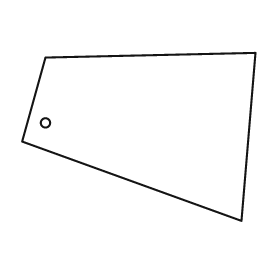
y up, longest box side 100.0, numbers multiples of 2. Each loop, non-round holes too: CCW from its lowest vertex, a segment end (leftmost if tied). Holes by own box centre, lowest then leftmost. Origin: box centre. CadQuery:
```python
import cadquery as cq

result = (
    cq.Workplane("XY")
    .moveTo(44.0, -36.0)
    .lineTo(50.0, 36.0)
    .lineTo(-40.0, 34.0)
    .lineTo(-50.0, -2.0)
    .close()
    .moveTo(-40.0, 6.0)
    .circle(2.0)
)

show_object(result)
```